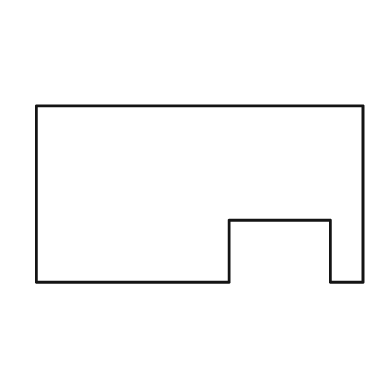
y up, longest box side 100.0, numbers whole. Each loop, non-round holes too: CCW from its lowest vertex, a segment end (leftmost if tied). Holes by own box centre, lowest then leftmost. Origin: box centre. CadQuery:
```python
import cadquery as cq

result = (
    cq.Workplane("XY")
    .moveTo(-50.0, -27.0)
    .lineTo(9.0, -27.0)
    .lineTo(9.0, -8.0)
    .lineTo(40.0, -8.0)
    .lineTo(40.0, -27.0)
    .lineTo(50.0, -27.0)
    .lineTo(50.0, 27.0)
    .lineTo(-50.0, 27.0)
    .close()
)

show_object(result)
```